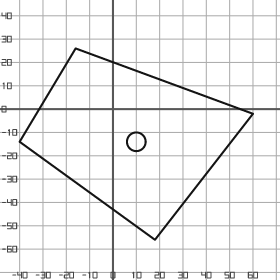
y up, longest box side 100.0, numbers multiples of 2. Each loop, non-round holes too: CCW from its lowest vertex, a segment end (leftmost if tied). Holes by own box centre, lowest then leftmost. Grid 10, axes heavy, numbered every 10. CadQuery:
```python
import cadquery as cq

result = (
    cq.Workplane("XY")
    .moveTo(18.0, -56.0)
    .lineTo(60.0, -2.0)
    .lineTo(-16.0, 26.0)
    .lineTo(-40.0, -14.0)
    .close()
    .moveTo(10.0, -14.0)
    .circle(4.0)
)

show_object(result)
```